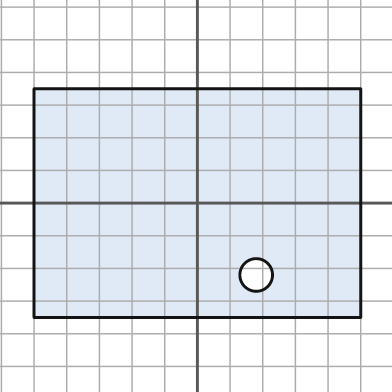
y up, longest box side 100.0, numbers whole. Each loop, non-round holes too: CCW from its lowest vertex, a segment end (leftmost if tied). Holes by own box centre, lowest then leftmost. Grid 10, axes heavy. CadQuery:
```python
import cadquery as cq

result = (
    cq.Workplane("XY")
    .moveTo(-50.0, -35.0)
    .lineTo(50.0, -35.0)
    .lineTo(50.0, 35.0)
    .lineTo(-50.0, 35.0)
    .close()
    .moveTo(18.0, -22.0)
    .circle(5.0)
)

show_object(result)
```